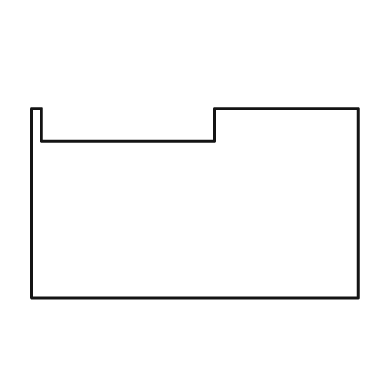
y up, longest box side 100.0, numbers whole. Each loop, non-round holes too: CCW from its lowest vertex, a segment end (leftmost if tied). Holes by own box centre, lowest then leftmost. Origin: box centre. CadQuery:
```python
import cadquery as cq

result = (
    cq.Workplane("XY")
    .moveTo(-50.0, -29.0)
    .lineTo(50.0, -29.0)
    .lineTo(50.0, 29.0)
    .lineTo(6.0, 29.0)
    .lineTo(6.0, 19.0)
    .lineTo(-47.0, 19.0)
    .lineTo(-47.0, 29.0)
    .lineTo(-50.0, 29.0)
    .close()
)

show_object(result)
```